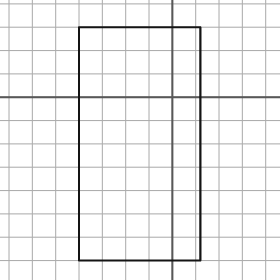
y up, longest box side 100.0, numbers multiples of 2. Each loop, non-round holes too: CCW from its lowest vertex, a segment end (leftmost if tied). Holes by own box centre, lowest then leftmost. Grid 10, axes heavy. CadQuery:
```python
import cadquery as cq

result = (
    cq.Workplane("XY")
    .moveTo(-40.0, -70.0)
    .lineTo(12.0, -70.0)
    .lineTo(12.0, 30.0)
    .lineTo(-40.0, 30.0)
    .close()
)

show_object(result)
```